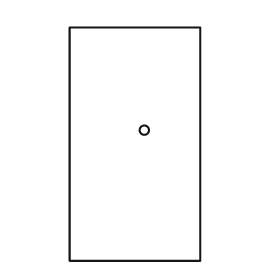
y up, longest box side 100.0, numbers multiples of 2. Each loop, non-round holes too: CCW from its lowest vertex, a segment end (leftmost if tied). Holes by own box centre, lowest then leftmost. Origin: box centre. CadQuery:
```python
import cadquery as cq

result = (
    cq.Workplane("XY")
    .moveTo(-28.0, -50.0)
    .lineTo(28.0, -50.0)
    .lineTo(28.0, 50.0)
    .lineTo(-28.0, 50.0)
    .close()
    .moveTo(4.0, 6.0)
    .circle(2.0)
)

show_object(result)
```